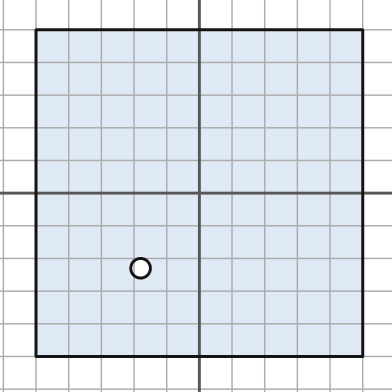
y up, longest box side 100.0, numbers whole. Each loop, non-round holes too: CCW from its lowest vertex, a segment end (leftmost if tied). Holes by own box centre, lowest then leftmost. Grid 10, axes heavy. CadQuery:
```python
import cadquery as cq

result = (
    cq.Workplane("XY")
    .moveTo(-50.0, -50.0)
    .lineTo(50.0, -50.0)
    .lineTo(50.0, 50.0)
    .lineTo(-50.0, 50.0)
    .close()
    .moveTo(-18.0, -23.0)
    .circle(3.0)
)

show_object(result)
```